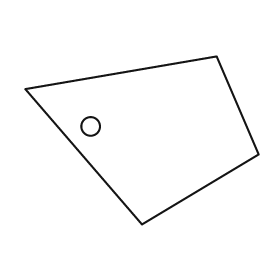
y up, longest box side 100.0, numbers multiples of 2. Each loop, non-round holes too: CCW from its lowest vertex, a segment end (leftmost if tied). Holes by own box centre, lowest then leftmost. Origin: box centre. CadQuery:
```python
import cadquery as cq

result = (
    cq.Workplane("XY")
    .moveTo(0.0, -36.0)
    .lineTo(50.0, -6.0)
    .lineTo(32.0, 36.0)
    .lineTo(-50.0, 22.0)
    .close()
    .moveTo(-22.0, 6.0)
    .circle(4.0)
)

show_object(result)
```